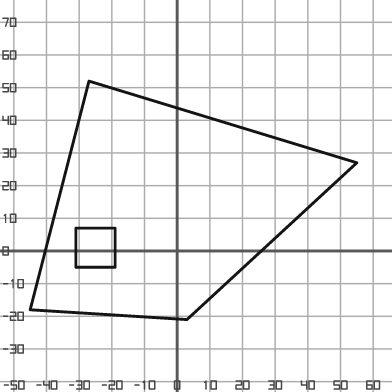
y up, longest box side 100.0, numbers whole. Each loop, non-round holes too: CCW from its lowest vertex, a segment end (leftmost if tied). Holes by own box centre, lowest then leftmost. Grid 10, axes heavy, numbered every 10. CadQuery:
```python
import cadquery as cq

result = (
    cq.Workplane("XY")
    .moveTo(3.0, -21.0)
    .lineTo(55.0, 27.0)
    .lineTo(-27.0, 52.0)
    .lineTo(-45.0, -18.0)
    .close()
    .moveTo(-31.0, -5.0)
    .lineTo(-19.0, -5.0)
    .lineTo(-19.0, 7.0)
    .lineTo(-31.0, 7.0)
    .close()
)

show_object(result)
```